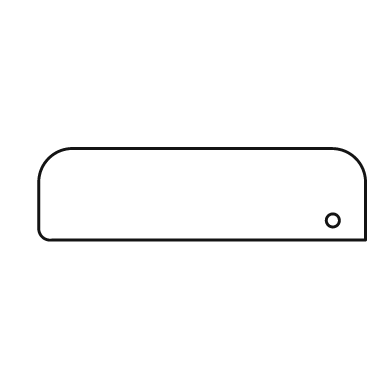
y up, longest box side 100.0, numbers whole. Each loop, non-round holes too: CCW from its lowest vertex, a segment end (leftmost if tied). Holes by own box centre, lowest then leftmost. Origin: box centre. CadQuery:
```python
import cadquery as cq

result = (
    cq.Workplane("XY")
    .moveTo(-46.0, -14.0)
    .lineTo(50.0, -14.0)
    .lineTo(50.0, 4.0)
    .threePointArc((47.0, 11.0), (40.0, 14.0))
    .lineTo(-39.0, 14.0)
    .threePointArc((-47.0, 11.0), (-50.0, 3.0))
    .lineTo(-50.0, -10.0)
    .threePointArc((-49.0, -13.0), (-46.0, -14.0))
    .close()
    .moveTo(40.0, -8.0)
    .circle(2.0)
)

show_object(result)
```